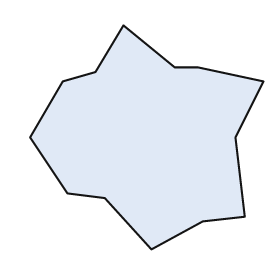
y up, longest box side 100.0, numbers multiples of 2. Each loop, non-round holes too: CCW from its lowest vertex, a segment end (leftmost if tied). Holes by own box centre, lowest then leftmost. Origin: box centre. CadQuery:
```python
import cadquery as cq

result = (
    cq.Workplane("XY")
    .moveTo(2.0, -48.0)
    .lineTo(24.0, -36.0)
    .lineTo(42.0, -34.0)
    .lineTo(38.0, 0.0)
    .lineTo(50.0, 24.0)
    .lineTo(22.0, 30.0)
    .lineTo(12.0, 30.0)
    .lineTo(-10.0, 48.0)
    .lineTo(-22.0, 28.0)
    .lineTo(-36.0, 24.0)
    .lineTo(-50.0, 0.0)
    .lineTo(-34.0, -24.0)
    .lineTo(-18.0, -26.0)
    .close()
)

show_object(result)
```